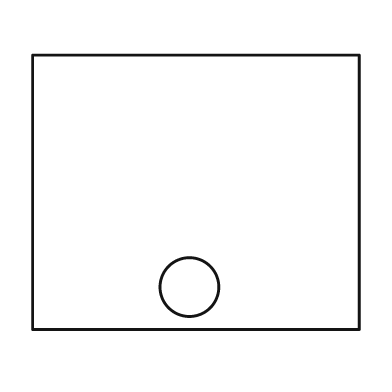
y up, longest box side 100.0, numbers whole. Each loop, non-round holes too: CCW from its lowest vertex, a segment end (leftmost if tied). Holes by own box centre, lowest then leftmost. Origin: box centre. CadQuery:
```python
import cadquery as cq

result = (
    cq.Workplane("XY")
    .moveTo(-50.0, -42.0)
    .lineTo(50.0, -42.0)
    .lineTo(50.0, 42.0)
    .lineTo(-50.0, 42.0)
    .close()
    .moveTo(-2.0, -29.0)
    .circle(9.0)
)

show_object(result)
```